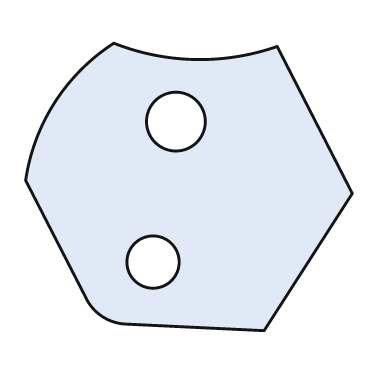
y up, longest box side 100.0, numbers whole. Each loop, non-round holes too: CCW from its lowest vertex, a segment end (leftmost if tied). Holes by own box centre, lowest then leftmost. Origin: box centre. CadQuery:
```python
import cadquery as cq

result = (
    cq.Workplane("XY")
    .moveTo(23.0, -44.0)
    .lineTo(50.0, -2.0)
    .lineTo(27.0, 43.0)
    .threePointArc((2.0, 39.0), (-23.0, 44.0))
    .threePointArc((-41.0, 26.0), (-50.0, 2.0))
    .lineTo(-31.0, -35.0)
    .threePointArc((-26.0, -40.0), (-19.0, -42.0))
    .close()
    .moveTo(-11.0, -23.0)
    .circle(8.0)
    .moveTo(-4.0, 20.0)
    .circle(9.0)
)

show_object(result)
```